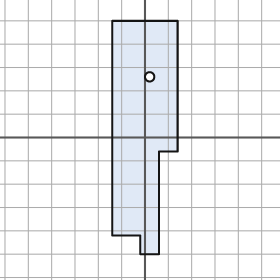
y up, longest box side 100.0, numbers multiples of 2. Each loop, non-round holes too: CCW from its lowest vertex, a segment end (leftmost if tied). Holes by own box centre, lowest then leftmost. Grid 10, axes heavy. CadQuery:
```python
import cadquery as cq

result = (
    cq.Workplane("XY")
    .moveTo(-2.0, -50.0)
    .lineTo(6.0, -50.0)
    .lineTo(6.0, -6.0)
    .lineTo(14.0, -6.0)
    .lineTo(14.0, 50.0)
    .lineTo(-14.0, 50.0)
    .lineTo(-14.0, -42.0)
    .lineTo(-2.0, -42.0)
    .close()
    .moveTo(2.0, 26.0)
    .circle(2.0)
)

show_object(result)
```